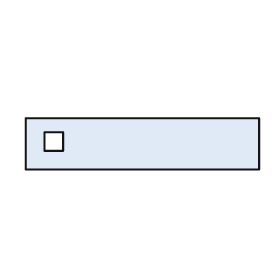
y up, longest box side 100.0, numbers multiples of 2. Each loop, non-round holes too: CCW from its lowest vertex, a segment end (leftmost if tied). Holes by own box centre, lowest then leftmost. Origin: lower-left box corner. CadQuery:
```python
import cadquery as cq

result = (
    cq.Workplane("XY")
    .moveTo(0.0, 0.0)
    .lineTo(100.0, 0.0)
    .lineTo(100.0, 22.0)
    .lineTo(0.0, 22.0)
    .close()
    .moveTo(8.0, 8.0)
    .lineTo(16.0, 8.0)
    .lineTo(16.0, 16.0)
    .lineTo(8.0, 16.0)
    .close()
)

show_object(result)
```